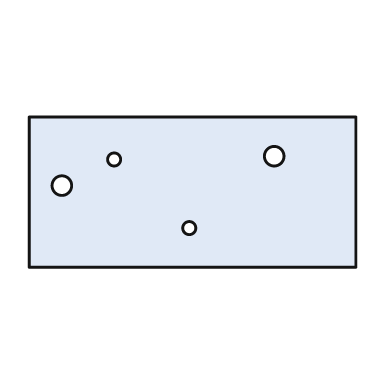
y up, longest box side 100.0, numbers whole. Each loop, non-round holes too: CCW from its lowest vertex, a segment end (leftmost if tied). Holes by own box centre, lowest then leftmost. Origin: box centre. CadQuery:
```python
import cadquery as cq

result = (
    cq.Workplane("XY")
    .moveTo(-50.0, -23.0)
    .lineTo(50.0, -23.0)
    .lineTo(50.0, 23.0)
    .lineTo(-50.0, 23.0)
    .close()
    .moveTo(-1.0, -11.0)
    .circle(2.0)
    .moveTo(-40.0, 2.0)
    .circle(3.0)
    .moveTo(-24.0, 10.0)
    .circle(2.0)
    .moveTo(25.0, 11.0)
    .circle(3.0)
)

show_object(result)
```